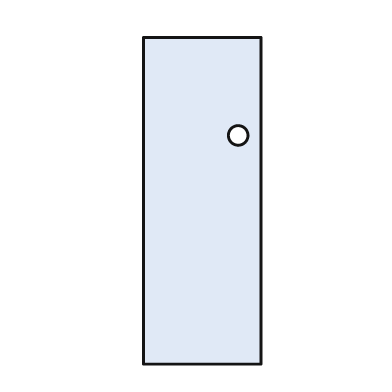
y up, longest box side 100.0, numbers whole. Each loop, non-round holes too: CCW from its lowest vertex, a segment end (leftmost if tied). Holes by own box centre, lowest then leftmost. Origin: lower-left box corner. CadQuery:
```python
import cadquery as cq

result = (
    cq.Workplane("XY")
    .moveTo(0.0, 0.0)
    .lineTo(36.0, 0.0)
    .lineTo(36.0, 100.0)
    .lineTo(0.0, 100.0)
    .close()
    .moveTo(29.0, 70.0)
    .circle(3.0)
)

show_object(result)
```